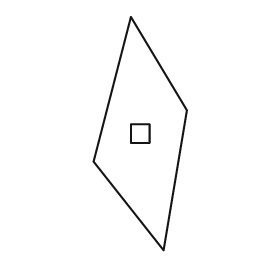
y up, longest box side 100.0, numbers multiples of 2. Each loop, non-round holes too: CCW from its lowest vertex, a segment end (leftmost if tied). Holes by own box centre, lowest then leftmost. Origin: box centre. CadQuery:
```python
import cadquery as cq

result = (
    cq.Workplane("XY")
    .moveTo(10.0, -50.0)
    .lineTo(20.0, 10.0)
    .lineTo(-4.0, 50.0)
    .lineTo(-20.0, -12.0)
    .close()
    .moveTo(-4.0, -4.0)
    .lineTo(4.0, -4.0)
    .lineTo(4.0, 4.0)
    .lineTo(-4.0, 4.0)
    .close()
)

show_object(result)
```